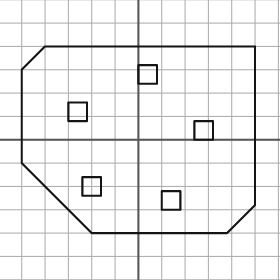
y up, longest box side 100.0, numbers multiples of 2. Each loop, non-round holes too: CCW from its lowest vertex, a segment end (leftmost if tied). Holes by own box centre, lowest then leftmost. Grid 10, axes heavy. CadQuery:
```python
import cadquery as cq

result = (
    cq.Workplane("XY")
    .moveTo(-20.0, -40.0)
    .lineTo(38.0, -40.0)
    .lineTo(50.0, -28.0)
    .lineTo(50.0, 40.0)
    .lineTo(-40.0, 40.0)
    .lineTo(-50.0, 30.0)
    .lineTo(-50.0, -10.0)
    .close()
    .moveTo(10.0, -30.0)
    .lineTo(18.0, -30.0)
    .lineTo(18.0, -22.0)
    .lineTo(10.0, -22.0)
    .close()
    .moveTo(-24.0, -24.0)
    .lineTo(-16.0, -24.0)
    .lineTo(-16.0, -16.0)
    .lineTo(-24.0, -16.0)
    .close()
    .moveTo(24.0, 0.0)
    .lineTo(32.0, 0.0)
    .lineTo(32.0, 8.0)
    .lineTo(24.0, 8.0)
    .close()
    .moveTo(-30.0, 8.0)
    .lineTo(-22.0, 8.0)
    .lineTo(-22.0, 16.0)
    .lineTo(-30.0, 16.0)
    .close()
    .moveTo(0.0, 24.0)
    .lineTo(8.0, 24.0)
    .lineTo(8.0, 32.0)
    .lineTo(0.0, 32.0)
    .close()
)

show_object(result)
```